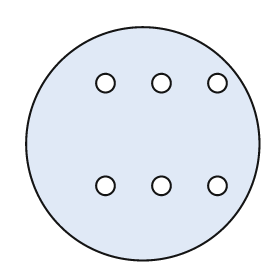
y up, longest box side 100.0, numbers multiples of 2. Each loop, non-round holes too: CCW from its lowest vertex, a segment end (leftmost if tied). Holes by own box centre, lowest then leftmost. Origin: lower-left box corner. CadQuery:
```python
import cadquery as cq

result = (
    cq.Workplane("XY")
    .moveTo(50.0, 50.0)
    .circle(50.0)
    .moveTo(34.0, 32.0)
    .circle(4.0)
    .moveTo(58.0, 32.0)
    .circle(4.0)
    .moveTo(82.0, 32.0)
    .circle(4.0)
    .moveTo(34.0, 76.0)
    .circle(4.0)
    .moveTo(58.0, 76.0)
    .circle(4.0)
    .moveTo(82.0, 76.0)
    .circle(4.0)
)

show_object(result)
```